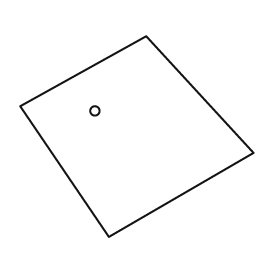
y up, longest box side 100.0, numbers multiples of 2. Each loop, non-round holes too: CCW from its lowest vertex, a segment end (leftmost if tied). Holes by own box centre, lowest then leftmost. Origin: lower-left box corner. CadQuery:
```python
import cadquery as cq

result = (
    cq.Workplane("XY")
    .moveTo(38.0, 0.0)
    .lineTo(100.0, 36.0)
    .lineTo(54.0, 86.0)
    .lineTo(0.0, 56.0)
    .close()
    .moveTo(32.0, 54.0)
    .circle(2.0)
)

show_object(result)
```